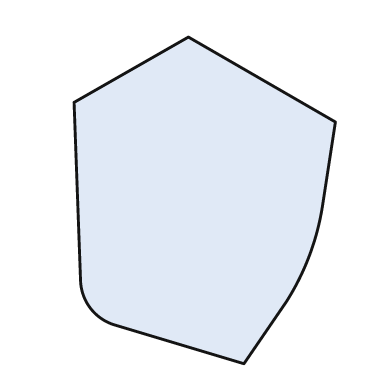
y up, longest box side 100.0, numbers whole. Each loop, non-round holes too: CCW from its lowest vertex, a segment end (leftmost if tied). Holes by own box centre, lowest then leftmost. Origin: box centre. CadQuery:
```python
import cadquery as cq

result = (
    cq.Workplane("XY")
    .moveTo(12.0, -50.0)
    .lineTo(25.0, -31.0)
    .threePointArc((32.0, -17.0), (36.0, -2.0))
    .lineTo(40.0, 24.0)
    .lineTo(-5.0, 50.0)
    .lineTo(-40.0, 30.0)
    .lineTo(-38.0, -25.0)
    .threePointArc((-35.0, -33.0), (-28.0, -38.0))
    .close()
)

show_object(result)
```